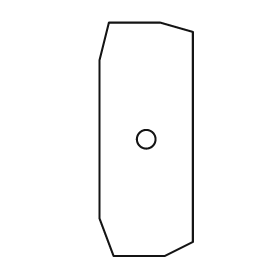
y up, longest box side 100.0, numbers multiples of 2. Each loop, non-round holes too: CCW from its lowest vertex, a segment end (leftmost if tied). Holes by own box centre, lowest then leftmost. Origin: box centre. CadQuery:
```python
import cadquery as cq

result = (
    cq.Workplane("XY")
    .moveTo(-14.0, -50.0)
    .lineTo(8.0, -50.0)
    .lineTo(20.0, -44.0)
    .lineTo(20.0, 46.0)
    .lineTo(6.0, 50.0)
    .lineTo(-16.0, 50.0)
    .lineTo(-20.0, 34.0)
    .lineTo(-20.0, -34.0)
    .close()
    .moveTo(0.0, 0.0)
    .circle(4.0)
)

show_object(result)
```